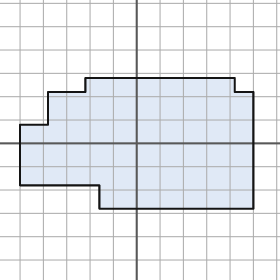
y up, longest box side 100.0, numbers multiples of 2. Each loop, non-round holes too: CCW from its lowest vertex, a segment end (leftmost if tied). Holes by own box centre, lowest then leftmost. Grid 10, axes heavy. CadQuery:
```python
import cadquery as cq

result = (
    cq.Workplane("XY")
    .moveTo(-16.0, -28.0)
    .lineTo(50.0, -28.0)
    .lineTo(50.0, 22.0)
    .lineTo(42.0, 22.0)
    .lineTo(42.0, 28.0)
    .lineTo(-22.0, 28.0)
    .lineTo(-22.0, 22.0)
    .lineTo(-38.0, 22.0)
    .lineTo(-38.0, 8.0)
    .lineTo(-50.0, 8.0)
    .lineTo(-50.0, -18.0)
    .lineTo(-16.0, -18.0)
    .close()
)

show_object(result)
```